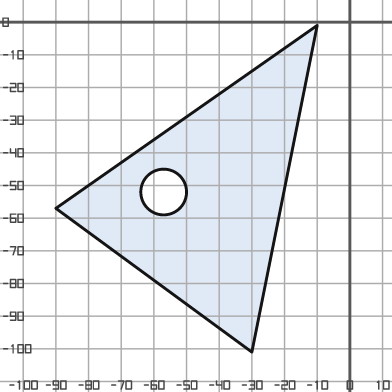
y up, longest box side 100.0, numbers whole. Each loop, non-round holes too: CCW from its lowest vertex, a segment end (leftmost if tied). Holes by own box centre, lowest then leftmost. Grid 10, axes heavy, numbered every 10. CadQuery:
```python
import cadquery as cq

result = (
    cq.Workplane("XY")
    .moveTo(-30.0, -101.0)
    .lineTo(-10.0, -1.0)
    .lineTo(-90.0, -57.0)
    .close()
    .moveTo(-57.0, -52.0)
    .circle(7.0)
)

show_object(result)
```